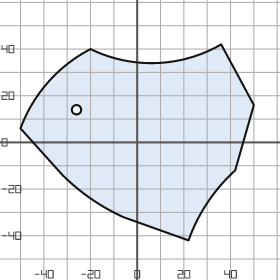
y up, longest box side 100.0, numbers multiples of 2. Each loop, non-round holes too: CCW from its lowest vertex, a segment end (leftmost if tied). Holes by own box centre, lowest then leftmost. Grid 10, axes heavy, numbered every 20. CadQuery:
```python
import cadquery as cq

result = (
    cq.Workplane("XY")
    .moveTo(22.0, -42.0)
    .threePointArc((30.0, -26.0), (42.0, -12.0))
    .lineTo(50.0, 16.0)
    .lineTo(36.0, 42.0)
    .threePointArc((8.0, 34.0), (-20.0, 40.0))
    .threePointArc((-38.0, 26.0), (-50.0, 6.0))
    .lineTo(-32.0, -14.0)
    .threePointArc((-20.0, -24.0), (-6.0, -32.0))
    .close()
    .moveTo(-26.0, 14.0)
    .circle(2.0)
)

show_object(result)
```